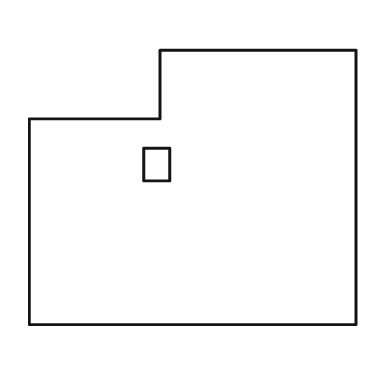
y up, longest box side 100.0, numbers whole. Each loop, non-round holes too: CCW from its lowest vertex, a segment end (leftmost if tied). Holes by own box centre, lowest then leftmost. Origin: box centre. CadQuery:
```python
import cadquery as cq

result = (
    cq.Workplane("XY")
    .moveTo(-50.0, -42.0)
    .lineTo(50.0, -42.0)
    .lineTo(50.0, 42.0)
    .lineTo(-10.0, 42.0)
    .lineTo(-10.0, 21.0)
    .lineTo(-50.0, 21.0)
    .close()
    .moveTo(-15.0, 2.0)
    .lineTo(-7.0, 2.0)
    .lineTo(-7.0, 12.0)
    .lineTo(-15.0, 12.0)
    .close()
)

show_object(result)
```